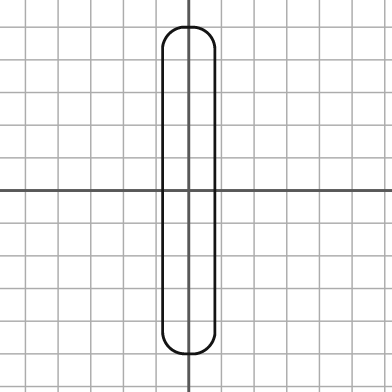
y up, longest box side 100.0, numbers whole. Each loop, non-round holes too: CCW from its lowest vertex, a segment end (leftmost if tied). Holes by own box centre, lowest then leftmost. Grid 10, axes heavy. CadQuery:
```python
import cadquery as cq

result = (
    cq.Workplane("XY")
    .moveTo(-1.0, -50.0)
    .lineTo(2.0, -50.0)
    .threePointArc((6.0, -48.0), (8.0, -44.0))
    .lineTo(8.0, 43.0)
    .threePointArc((6.0, 48.0), (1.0, 50.0))
    .lineTo(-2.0, 50.0)
    .threePointArc((-6.0, 48.0), (-8.0, 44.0))
    .lineTo(-8.0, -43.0)
    .threePointArc((-6.0, -48.0), (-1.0, -50.0))
    .close()
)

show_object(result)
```